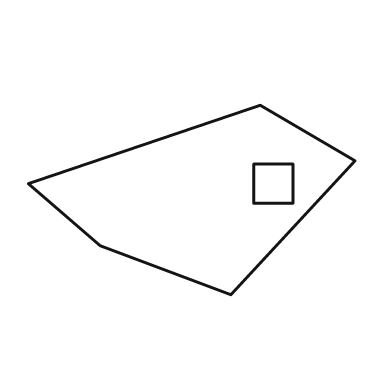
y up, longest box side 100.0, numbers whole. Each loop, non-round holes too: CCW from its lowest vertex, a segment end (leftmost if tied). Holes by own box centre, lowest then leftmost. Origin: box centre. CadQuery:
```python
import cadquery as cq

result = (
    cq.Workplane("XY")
    .moveTo(12.0, -29.0)
    .lineTo(50.0, 12.0)
    .lineTo(21.0, 29.0)
    .lineTo(-50.0, 5.0)
    .lineTo(-28.0, -14.0)
    .close()
    .moveTo(19.0, -1.0)
    .lineTo(31.0, -1.0)
    .lineTo(31.0, 11.0)
    .lineTo(19.0, 11.0)
    .close()
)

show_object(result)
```